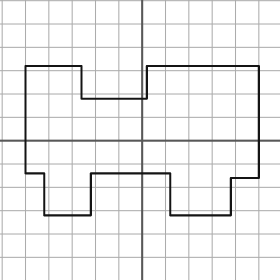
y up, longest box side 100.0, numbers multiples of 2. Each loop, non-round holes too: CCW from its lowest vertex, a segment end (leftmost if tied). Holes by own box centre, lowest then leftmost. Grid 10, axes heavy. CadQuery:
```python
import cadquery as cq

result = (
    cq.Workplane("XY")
    .moveTo(-42.0, -32.0)
    .lineTo(-22.0, -32.0)
    .lineTo(-22.0, -14.0)
    .lineTo(12.0, -14.0)
    .lineTo(12.0, -32.0)
    .lineTo(38.0, -32.0)
    .lineTo(38.0, -16.0)
    .lineTo(50.0, -16.0)
    .lineTo(50.0, 32.0)
    .lineTo(2.0, 32.0)
    .lineTo(2.0, 18.0)
    .lineTo(-26.0, 18.0)
    .lineTo(-26.0, 32.0)
    .lineTo(-50.0, 32.0)
    .lineTo(-50.0, -14.0)
    .lineTo(-42.0, -14.0)
    .close()
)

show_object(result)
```